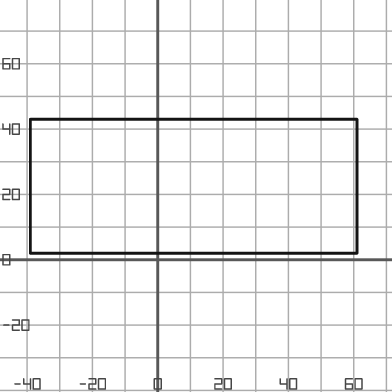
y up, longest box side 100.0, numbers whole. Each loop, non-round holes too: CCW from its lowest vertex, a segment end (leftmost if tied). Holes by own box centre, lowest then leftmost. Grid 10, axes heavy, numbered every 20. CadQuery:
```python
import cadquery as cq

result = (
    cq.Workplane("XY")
    .moveTo(-39.0, 2.0)
    .lineTo(61.0, 2.0)
    .lineTo(61.0, 43.0)
    .lineTo(-39.0, 43.0)
    .close()
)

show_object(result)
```